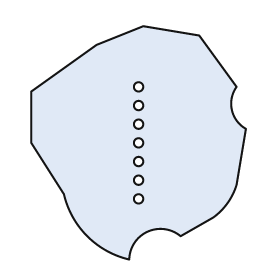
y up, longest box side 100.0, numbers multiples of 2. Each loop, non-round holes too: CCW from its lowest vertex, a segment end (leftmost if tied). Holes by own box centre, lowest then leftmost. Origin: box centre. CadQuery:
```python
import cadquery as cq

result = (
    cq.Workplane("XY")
    .moveTo(-4.0, -50.0)
    .threePointArc((4.0, -38.0), (18.0, -40.0))
    .lineTo(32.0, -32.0)
    .threePointArc((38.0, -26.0), (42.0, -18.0))
    .lineTo(46.0, 6.0)
    .threePointArc((40.0, 14.0), (42.0, 24.0))
    .lineTo(26.0, 46.0)
    .lineTo(2.0, 50.0)
    .lineTo(-18.0, 42.0)
    .lineTo(-46.0, 22.0)
    .lineTo(-46.0, 0.0)
    .lineTo(-32.0, -22.0)
    .threePointArc((-22.0, -40.0), (-4.0, -50.0))
    .close()
    .moveTo(0.0, -24.0)
    .circle(2.0)
    .moveTo(0.0, -16.0)
    .circle(2.0)
    .moveTo(0.0, -8.0)
    .circle(2.0)
    .moveTo(0.0, 0.0)
    .circle(2.0)
    .moveTo(0.0, 8.0)
    .circle(2.0)
    .moveTo(0.0, 16.0)
    .circle(2.0)
    .moveTo(0.0, 24.0)
    .circle(2.0)
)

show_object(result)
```